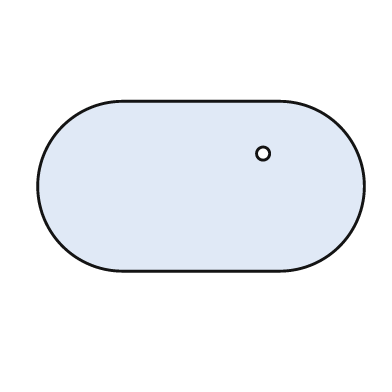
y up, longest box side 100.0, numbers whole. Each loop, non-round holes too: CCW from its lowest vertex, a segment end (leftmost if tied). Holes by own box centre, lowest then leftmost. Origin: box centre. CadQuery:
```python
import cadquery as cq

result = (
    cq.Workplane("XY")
    .moveTo(-24.0, -26.0)
    .lineTo(24.0, -26.0)
    .threePointArc((50.0, 0.0), (24.0, 26.0))
    .lineTo(-24.0, 26.0)
    .threePointArc((-50.0, 0.0), (-24.0, -26.0))
    .close()
    .moveTo(19.0, 10.0)
    .circle(2.0)
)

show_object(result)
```